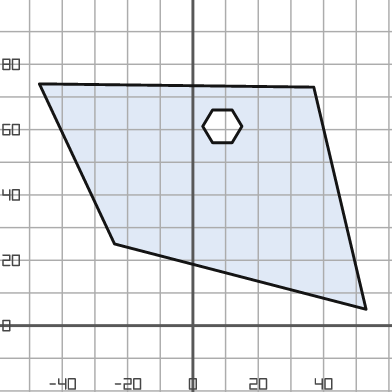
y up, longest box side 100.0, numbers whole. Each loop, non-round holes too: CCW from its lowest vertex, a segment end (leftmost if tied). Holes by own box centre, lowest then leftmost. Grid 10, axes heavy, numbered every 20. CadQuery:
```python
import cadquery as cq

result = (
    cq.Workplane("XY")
    .moveTo(53.0, 5.0)
    .lineTo(37.0, 73.0)
    .lineTo(-47.0, 74.0)
    .lineTo(-24.0, 25.0)
    .close()
    .moveTo(6.0, 56.0)
    .lineTo(12.0, 56.0)
    .lineTo(15.0, 61.0)
    .lineTo(12.0, 66.0)
    .lineTo(6.0, 66.0)
    .lineTo(3.0, 61.0)
    .close()
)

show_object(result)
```